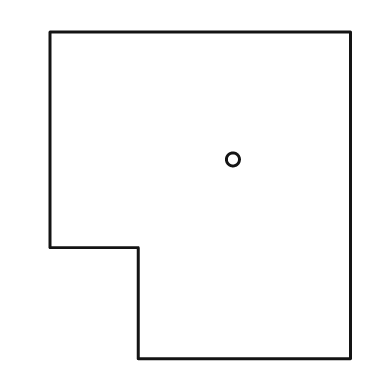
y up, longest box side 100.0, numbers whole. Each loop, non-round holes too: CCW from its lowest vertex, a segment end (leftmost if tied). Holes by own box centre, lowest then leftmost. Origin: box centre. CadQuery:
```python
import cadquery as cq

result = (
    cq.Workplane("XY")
    .moveTo(-19.0, -50.0)
    .lineTo(46.0, -50.0)
    .lineTo(46.0, 50.0)
    .lineTo(-46.0, 50.0)
    .lineTo(-46.0, -16.0)
    .lineTo(-19.0, -16.0)
    .close()
    .moveTo(10.0, 11.0)
    .circle(2.0)
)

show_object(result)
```